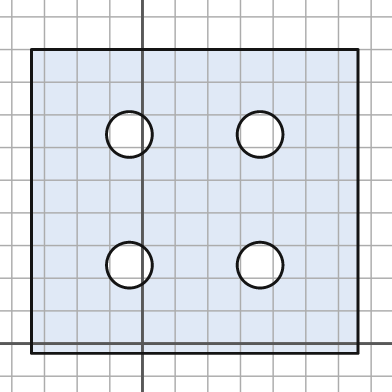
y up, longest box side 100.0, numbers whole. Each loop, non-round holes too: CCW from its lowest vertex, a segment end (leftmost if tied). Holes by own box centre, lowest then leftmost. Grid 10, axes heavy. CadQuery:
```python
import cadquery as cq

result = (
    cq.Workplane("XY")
    .moveTo(-34.0, -3.0)
    .lineTo(66.0, -3.0)
    .lineTo(66.0, 90.0)
    .lineTo(-34.0, 90.0)
    .close()
    .moveTo(-4.0, 24.0)
    .circle(7.0)
    .moveTo(36.0, 24.0)
    .circle(7.0)
    .moveTo(-4.0, 64.0)
    .circle(7.0)
    .moveTo(36.0, 64.0)
    .circle(7.0)
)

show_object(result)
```